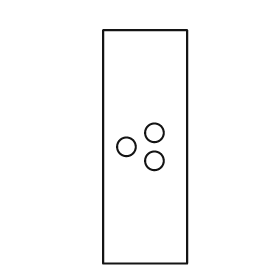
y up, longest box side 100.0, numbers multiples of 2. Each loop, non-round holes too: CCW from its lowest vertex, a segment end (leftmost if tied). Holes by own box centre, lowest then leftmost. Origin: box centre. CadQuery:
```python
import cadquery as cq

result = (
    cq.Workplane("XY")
    .moveTo(-18.0, -50.0)
    .lineTo(18.0, -50.0)
    .lineTo(18.0, 50.0)
    .lineTo(-18.0, 50.0)
    .close()
    .moveTo(4.0, -6.0)
    .circle(4.0)
    .moveTo(-8.0, 0.0)
    .circle(4.0)
    .moveTo(4.0, 6.0)
    .circle(4.0)
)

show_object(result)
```